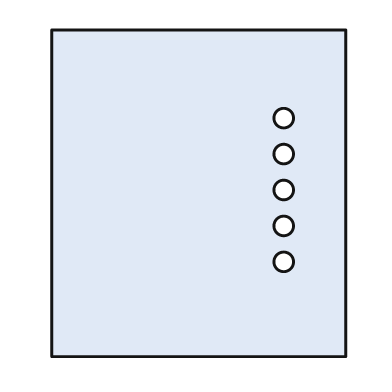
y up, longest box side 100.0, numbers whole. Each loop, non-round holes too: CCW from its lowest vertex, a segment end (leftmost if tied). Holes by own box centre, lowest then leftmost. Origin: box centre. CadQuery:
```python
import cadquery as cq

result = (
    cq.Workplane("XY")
    .moveTo(-45.0, -50.0)
    .lineTo(45.0, -50.0)
    .lineTo(45.0, 50.0)
    .lineTo(-45.0, 50.0)
    .close()
    .moveTo(26.0, -21.0)
    .circle(3.0)
    .moveTo(26.0, -10.0)
    .circle(3.0)
    .moveTo(26.0, 1.0)
    .circle(3.0)
    .moveTo(26.0, 12.0)
    .circle(3.0)
    .moveTo(26.0, 23.0)
    .circle(3.0)
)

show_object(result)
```